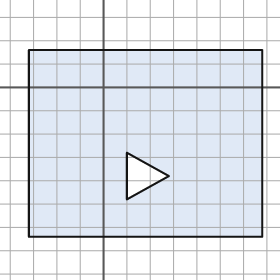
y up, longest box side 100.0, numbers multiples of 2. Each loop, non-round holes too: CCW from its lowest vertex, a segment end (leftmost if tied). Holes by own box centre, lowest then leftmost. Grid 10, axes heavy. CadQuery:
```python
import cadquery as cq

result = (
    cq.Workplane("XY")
    .moveTo(-32.0, -64.0)
    .lineTo(68.0, -64.0)
    .lineTo(68.0, 16.0)
    .lineTo(-32.0, 16.0)
    .close()
    .moveTo(10.0, -48.0)
    .lineTo(28.0, -38.0)
    .lineTo(10.0, -28.0)
    .close()
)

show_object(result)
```